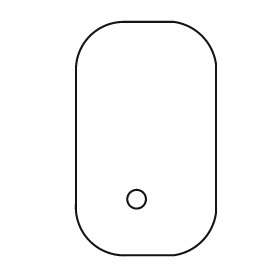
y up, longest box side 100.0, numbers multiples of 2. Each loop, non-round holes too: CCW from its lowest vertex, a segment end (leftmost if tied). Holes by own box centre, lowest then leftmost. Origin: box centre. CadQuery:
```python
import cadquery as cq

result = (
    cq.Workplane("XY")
    .moveTo(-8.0, -50.0)
    .lineTo(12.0, -50.0)
    .threePointArc((24.0, -44.0), (30.0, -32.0))
    .lineTo(30.0, 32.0)
    .threePointArc((24.0, 44.0), (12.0, 50.0))
    .lineTo(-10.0, 50.0)
    .threePointArc((-24.0, 44.0), (-30.0, 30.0))
    .lineTo(-30.0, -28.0)
    .threePointArc((-24.0, -44.0), (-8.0, -50.0))
    .close()
    .moveTo(-4.0, -26.0)
    .circle(4.0)
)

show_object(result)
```